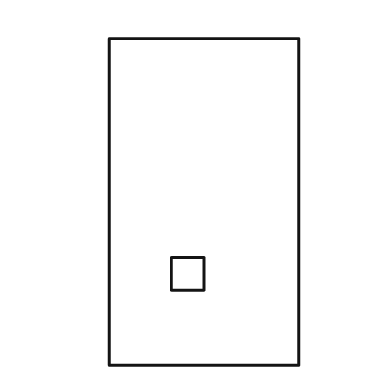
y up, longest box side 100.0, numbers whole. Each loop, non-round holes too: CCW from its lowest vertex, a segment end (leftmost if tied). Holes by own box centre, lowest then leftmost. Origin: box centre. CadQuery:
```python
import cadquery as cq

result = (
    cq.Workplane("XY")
    .moveTo(-29.0, -50.0)
    .lineTo(29.0, -50.0)
    .lineTo(29.0, 50.0)
    .lineTo(-29.0, 50.0)
    .close()
    .moveTo(-10.0, -27.0)
    .lineTo(0.0, -27.0)
    .lineTo(0.0, -17.0)
    .lineTo(-10.0, -17.0)
    .close()
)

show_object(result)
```